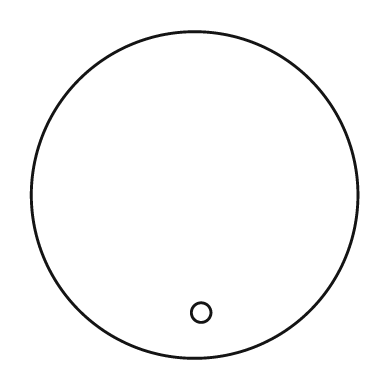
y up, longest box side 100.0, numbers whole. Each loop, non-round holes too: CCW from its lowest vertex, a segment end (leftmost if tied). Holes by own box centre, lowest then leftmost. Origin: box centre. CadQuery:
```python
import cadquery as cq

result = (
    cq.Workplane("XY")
    .moveTo(0.0, 0.0)
    .circle(50.0)
    .moveTo(2.0, -36.0)
    .circle(3.0)
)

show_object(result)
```